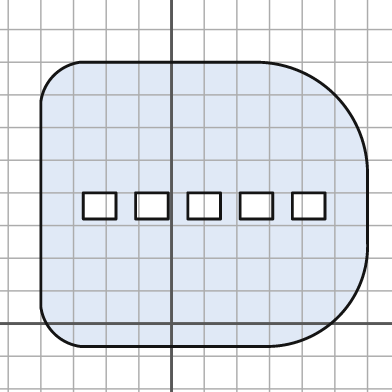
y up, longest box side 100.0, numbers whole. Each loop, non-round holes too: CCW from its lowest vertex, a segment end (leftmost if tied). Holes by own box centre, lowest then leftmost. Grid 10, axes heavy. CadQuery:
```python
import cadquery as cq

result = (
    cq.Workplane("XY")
    .moveTo(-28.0, -7.0)
    .lineTo(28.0, -7.0)
    .threePointArc((51.0, 2.0), (60.0, 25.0))
    .lineTo(60.0, 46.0)
    .threePointArc((50.0, 70.0), (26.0, 80.0))
    .lineTo(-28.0, 80.0)
    .threePointArc((-36.0, 76.0), (-40.0, 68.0))
    .lineTo(-40.0, 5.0)
    .threePointArc((-36.0, -3.0), (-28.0, -7.0))
    .close()
    .moveTo(-27.0, 32.0)
    .lineTo(-17.0, 32.0)
    .lineTo(-17.0, 40.0)
    .lineTo(-27.0, 40.0)
    .close()
    .moveTo(-11.0, 32.0)
    .lineTo(-1.0, 32.0)
    .lineTo(-1.0, 40.0)
    .lineTo(-11.0, 40.0)
    .close()
    .moveTo(5.0, 32.0)
    .lineTo(15.0, 32.0)
    .lineTo(15.0, 40.0)
    .lineTo(5.0, 40.0)
    .close()
    .moveTo(21.0, 32.0)
    .lineTo(31.0, 32.0)
    .lineTo(31.0, 40.0)
    .lineTo(21.0, 40.0)
    .close()
    .moveTo(37.0, 32.0)
    .lineTo(47.0, 32.0)
    .lineTo(47.0, 40.0)
    .lineTo(37.0, 40.0)
    .close()
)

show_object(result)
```